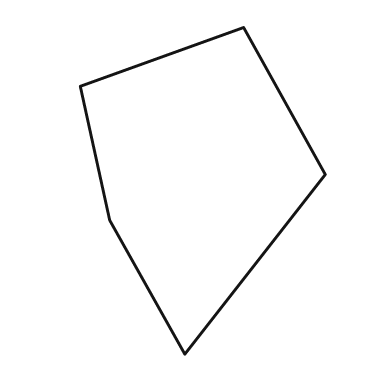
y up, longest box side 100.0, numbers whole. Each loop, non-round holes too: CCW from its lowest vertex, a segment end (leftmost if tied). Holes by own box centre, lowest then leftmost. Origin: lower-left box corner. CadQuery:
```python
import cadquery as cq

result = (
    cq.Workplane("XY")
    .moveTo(32.0, 0.0)
    .lineTo(75.0, 55.0)
    .lineTo(50.0, 100.0)
    .lineTo(0.0, 82.0)
    .lineTo(9.0, 41.0)
    .close()
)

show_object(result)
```